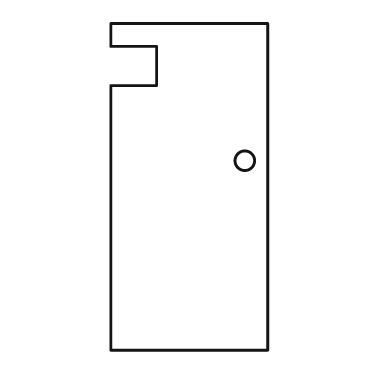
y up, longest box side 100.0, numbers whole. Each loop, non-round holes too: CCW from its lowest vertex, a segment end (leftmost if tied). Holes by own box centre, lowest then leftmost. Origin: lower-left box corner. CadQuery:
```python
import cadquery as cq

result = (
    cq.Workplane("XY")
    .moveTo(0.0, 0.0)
    .lineTo(48.0, 0.0)
    .lineTo(48.0, 100.0)
    .lineTo(0.0, 100.0)
    .lineTo(0.0, 93.0)
    .lineTo(14.0, 93.0)
    .lineTo(14.0, 81.0)
    .lineTo(0.0, 81.0)
    .close()
    .moveTo(41.0, 58.0)
    .circle(3.0)
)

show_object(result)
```